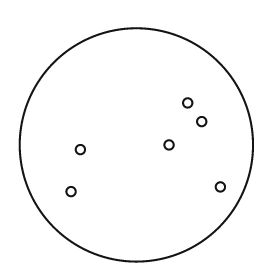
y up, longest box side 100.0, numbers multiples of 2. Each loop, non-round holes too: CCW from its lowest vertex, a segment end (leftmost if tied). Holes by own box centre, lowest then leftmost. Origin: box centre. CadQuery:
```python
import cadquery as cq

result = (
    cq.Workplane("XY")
    .moveTo(0.0, 0.0)
    .circle(50.0)
    .moveTo(-28.0, -20.0)
    .circle(2.0)
    .moveTo(36.0, -18.0)
    .circle(2.0)
    .moveTo(-24.0, -2.0)
    .circle(2.0)
    .moveTo(14.0, 0.0)
    .circle(2.0)
    .moveTo(28.0, 10.0)
    .circle(2.0)
    .moveTo(22.0, 18.0)
    .circle(2.0)
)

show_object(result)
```